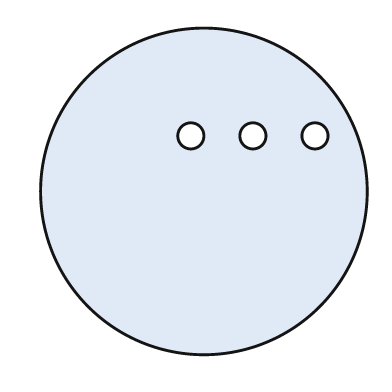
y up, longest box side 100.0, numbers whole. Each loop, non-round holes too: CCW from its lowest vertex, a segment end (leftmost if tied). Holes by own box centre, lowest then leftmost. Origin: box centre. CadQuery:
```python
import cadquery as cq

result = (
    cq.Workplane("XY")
    .moveTo(0.0, 0.0)
    .circle(50.0)
    .moveTo(-4.0, 17.0)
    .circle(4.0)
    .moveTo(15.0, 17.0)
    .circle(4.0)
    .moveTo(34.0, 17.0)
    .circle(4.0)
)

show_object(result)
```